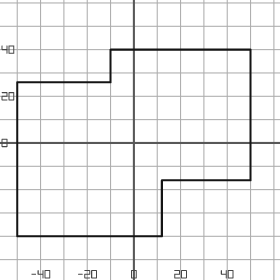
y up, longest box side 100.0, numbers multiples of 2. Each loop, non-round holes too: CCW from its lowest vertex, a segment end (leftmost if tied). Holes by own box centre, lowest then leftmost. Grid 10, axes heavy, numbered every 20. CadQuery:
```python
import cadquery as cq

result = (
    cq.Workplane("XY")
    .moveTo(-50.0, -40.0)
    .lineTo(12.0, -40.0)
    .lineTo(12.0, -16.0)
    .lineTo(50.0, -16.0)
    .lineTo(50.0, 40.0)
    .lineTo(-10.0, 40.0)
    .lineTo(-10.0, 26.0)
    .lineTo(-50.0, 26.0)
    .close()
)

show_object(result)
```